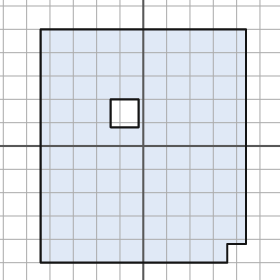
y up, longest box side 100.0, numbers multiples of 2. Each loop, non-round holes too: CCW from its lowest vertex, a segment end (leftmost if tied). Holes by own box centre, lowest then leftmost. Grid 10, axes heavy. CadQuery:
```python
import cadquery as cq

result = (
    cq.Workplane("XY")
    .moveTo(-44.0, -50.0)
    .lineTo(36.0, -50.0)
    .lineTo(36.0, -42.0)
    .lineTo(44.0, -42.0)
    .lineTo(44.0, 50.0)
    .lineTo(-44.0, 50.0)
    .close()
    .moveTo(-14.0, 8.0)
    .lineTo(-2.0, 8.0)
    .lineTo(-2.0, 20.0)
    .lineTo(-14.0, 20.0)
    .close()
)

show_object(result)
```